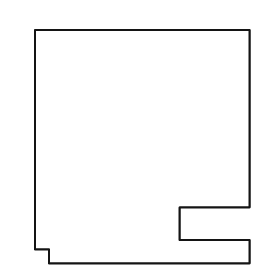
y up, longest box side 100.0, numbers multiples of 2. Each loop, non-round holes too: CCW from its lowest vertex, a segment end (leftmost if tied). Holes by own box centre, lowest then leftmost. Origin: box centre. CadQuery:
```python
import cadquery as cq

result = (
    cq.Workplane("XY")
    .moveTo(-40.0, -50.0)
    .lineTo(46.0, -50.0)
    .lineTo(46.0, -40.0)
    .lineTo(16.0, -40.0)
    .lineTo(16.0, -26.0)
    .lineTo(46.0, -26.0)
    .lineTo(46.0, 50.0)
    .lineTo(-46.0, 50.0)
    .lineTo(-46.0, -44.0)
    .lineTo(-40.0, -44.0)
    .close()
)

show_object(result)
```